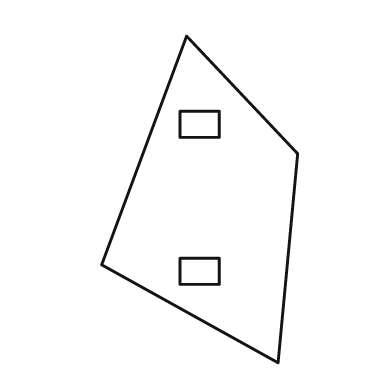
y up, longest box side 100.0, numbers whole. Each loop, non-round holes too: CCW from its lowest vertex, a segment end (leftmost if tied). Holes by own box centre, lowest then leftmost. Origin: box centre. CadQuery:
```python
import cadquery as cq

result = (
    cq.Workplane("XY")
    .moveTo(24.0, -50.0)
    .lineTo(30.0, 14.0)
    .lineTo(-4.0, 50.0)
    .lineTo(-30.0, -20.0)
    .close()
    .moveTo(-6.0, -26.0)
    .lineTo(6.0, -26.0)
    .lineTo(6.0, -18.0)
    .lineTo(-6.0, -18.0)
    .close()
    .moveTo(-6.0, 19.0)
    .lineTo(6.0, 19.0)
    .lineTo(6.0, 27.0)
    .lineTo(-6.0, 27.0)
    .close()
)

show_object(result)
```